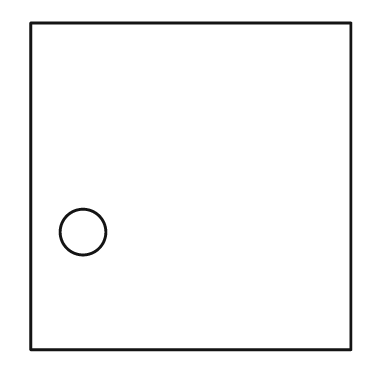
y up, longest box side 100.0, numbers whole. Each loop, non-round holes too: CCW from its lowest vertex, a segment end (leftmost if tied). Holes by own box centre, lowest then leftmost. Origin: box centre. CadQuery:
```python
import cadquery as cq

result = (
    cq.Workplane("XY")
    .moveTo(-49.0, -50.0)
    .lineTo(49.0, -50.0)
    .lineTo(49.0, 50.0)
    .lineTo(-49.0, 50.0)
    .close()
    .moveTo(-33.0, -14.0)
    .circle(7.0)
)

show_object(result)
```